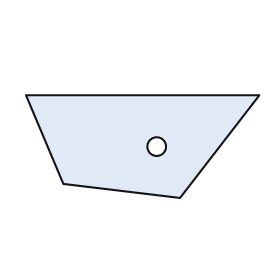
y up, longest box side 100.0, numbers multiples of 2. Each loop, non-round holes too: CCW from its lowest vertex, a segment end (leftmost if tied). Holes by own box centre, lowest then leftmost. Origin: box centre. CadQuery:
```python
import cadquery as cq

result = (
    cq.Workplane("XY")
    .moveTo(16.0, -22.0)
    .lineTo(50.0, 22.0)
    .lineTo(-50.0, 22.0)
    .lineTo(-34.0, -16.0)
    .close()
    .moveTo(6.0, 0.0)
    .circle(4.0)
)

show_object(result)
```